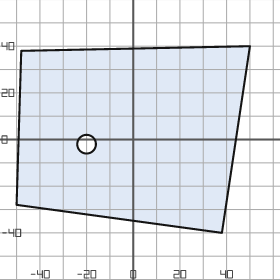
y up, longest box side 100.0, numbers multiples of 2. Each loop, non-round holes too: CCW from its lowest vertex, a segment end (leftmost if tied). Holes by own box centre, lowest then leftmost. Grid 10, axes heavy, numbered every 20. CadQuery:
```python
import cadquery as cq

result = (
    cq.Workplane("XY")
    .moveTo(38.0, -40.0)
    .lineTo(50.0, 40.0)
    .lineTo(-48.0, 38.0)
    .lineTo(-50.0, -28.0)
    .close()
    .moveTo(-20.0, -2.0)
    .circle(4.0)
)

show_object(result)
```